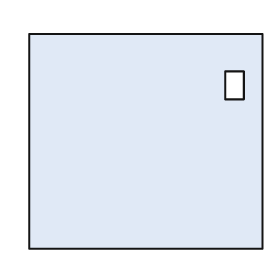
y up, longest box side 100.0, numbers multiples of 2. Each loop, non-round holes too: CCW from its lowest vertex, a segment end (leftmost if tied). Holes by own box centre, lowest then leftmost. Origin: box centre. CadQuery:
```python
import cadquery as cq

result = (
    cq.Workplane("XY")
    .moveTo(-50.0, -46.0)
    .lineTo(50.0, -46.0)
    .lineTo(50.0, 46.0)
    .lineTo(-50.0, 46.0)
    .close()
    .moveTo(34.0, 18.0)
    .lineTo(42.0, 18.0)
    .lineTo(42.0, 30.0)
    .lineTo(34.0, 30.0)
    .close()
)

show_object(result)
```